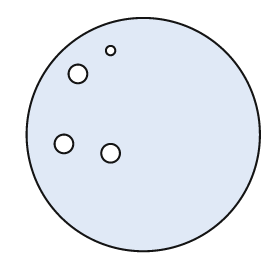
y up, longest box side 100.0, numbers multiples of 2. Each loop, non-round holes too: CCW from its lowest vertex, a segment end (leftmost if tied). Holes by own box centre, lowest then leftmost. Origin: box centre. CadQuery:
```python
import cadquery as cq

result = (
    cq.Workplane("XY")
    .moveTo(0.0, 0.0)
    .circle(50.0)
    .moveTo(-14.0, -8.0)
    .circle(4.0)
    .moveTo(-34.0, -4.0)
    .circle(4.0)
    .moveTo(-28.0, 26.0)
    .circle(4.0)
    .moveTo(-14.0, 36.0)
    .circle(2.0)
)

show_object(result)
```